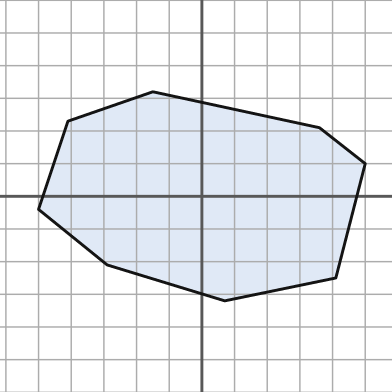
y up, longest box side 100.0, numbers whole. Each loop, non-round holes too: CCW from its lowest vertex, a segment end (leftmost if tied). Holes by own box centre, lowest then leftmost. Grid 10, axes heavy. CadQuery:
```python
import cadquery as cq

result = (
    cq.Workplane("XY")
    .moveTo(7.0, -32.0)
    .lineTo(41.0, -25.0)
    .lineTo(50.0, 10.0)
    .lineTo(36.0, 21.0)
    .lineTo(-15.0, 32.0)
    .lineTo(-41.0, 23.0)
    .lineTo(-50.0, -4.0)
    .lineTo(-29.0, -21.0)
    .close()
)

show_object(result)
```